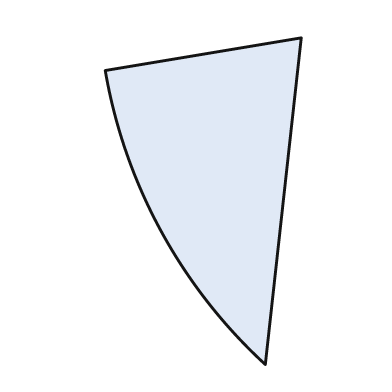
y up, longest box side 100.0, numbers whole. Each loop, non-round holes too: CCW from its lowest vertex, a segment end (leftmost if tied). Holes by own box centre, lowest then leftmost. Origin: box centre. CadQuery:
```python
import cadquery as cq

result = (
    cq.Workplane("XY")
    .moveTo(19.0, -50.0)
    .lineTo(30.0, 50.0)
    .lineTo(-30.0, 40.0)
    .threePointArc((-13.0, -9.0), (19.0, -50.0))
    .close()
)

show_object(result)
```